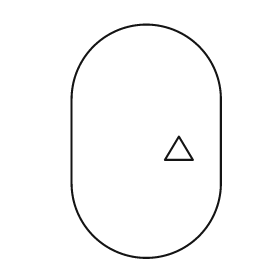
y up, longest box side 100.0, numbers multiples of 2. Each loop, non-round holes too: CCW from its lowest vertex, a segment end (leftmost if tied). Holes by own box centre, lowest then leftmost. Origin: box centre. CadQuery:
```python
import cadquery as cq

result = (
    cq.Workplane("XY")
    .moveTo(-32.0, -18.0)
    .threePointArc((0.0, -50.0), (32.0, -18.0))
    .lineTo(32.0, 18.0)
    .threePointArc((0.0, 50.0), (-32.0, 18.0))
    .close()
    .moveTo(8.0, -8.0)
    .lineTo(20.0, -8.0)
    .lineTo(14.0, 2.0)
    .close()
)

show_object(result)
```